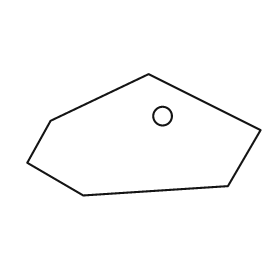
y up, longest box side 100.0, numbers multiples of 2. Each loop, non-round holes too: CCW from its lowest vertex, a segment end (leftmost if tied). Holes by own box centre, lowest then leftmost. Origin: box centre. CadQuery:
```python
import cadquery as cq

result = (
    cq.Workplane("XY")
    .moveTo(-26.0, -26.0)
    .lineTo(36.0, -22.0)
    .lineTo(50.0, 2.0)
    .lineTo(2.0, 26.0)
    .lineTo(-40.0, 6.0)
    .lineTo(-50.0, -12.0)
    .close()
    .moveTo(8.0, 8.0)
    .circle(4.0)
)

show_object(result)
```